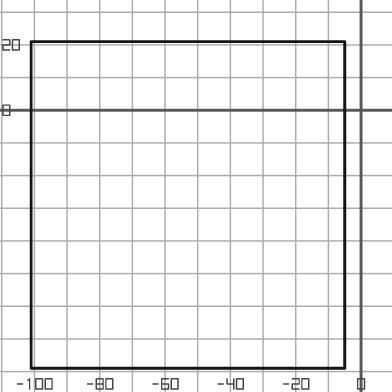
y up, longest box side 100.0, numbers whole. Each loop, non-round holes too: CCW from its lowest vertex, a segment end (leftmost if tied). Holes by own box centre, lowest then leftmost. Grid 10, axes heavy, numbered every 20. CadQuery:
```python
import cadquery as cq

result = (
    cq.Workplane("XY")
    .moveTo(-101.0, -79.0)
    .lineTo(-5.0, -79.0)
    .lineTo(-5.0, 21.0)
    .lineTo(-101.0, 21.0)
    .close()
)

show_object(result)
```